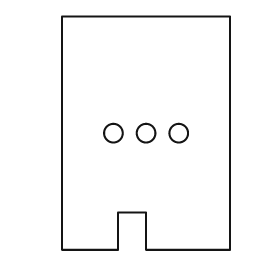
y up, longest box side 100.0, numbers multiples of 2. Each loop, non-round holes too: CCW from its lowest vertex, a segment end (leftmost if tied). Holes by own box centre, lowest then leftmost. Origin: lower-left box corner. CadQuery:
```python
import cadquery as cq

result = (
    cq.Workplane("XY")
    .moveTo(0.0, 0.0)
    .lineTo(24.0, 0.0)
    .lineTo(24.0, 16.0)
    .lineTo(36.0, 16.0)
    .lineTo(36.0, 0.0)
    .lineTo(72.0, 0.0)
    .lineTo(72.0, 100.0)
    .lineTo(0.0, 100.0)
    .close()
    .moveTo(22.0, 50.0)
    .circle(4.0)
    .moveTo(36.0, 50.0)
    .circle(4.0)
    .moveTo(50.0, 50.0)
    .circle(4.0)
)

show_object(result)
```